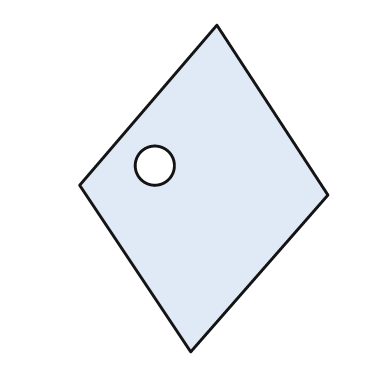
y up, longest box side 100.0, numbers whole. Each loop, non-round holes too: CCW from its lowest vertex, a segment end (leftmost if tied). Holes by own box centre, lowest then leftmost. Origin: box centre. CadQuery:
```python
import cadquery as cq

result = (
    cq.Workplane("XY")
    .moveTo(-4.0, -50.0)
    .lineTo(38.0, -2.0)
    .lineTo(4.0, 50.0)
    .lineTo(-38.0, 1.0)
    .close()
    .moveTo(-15.0, 7.0)
    .circle(6.0)
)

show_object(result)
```